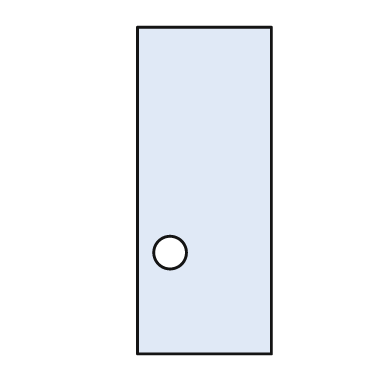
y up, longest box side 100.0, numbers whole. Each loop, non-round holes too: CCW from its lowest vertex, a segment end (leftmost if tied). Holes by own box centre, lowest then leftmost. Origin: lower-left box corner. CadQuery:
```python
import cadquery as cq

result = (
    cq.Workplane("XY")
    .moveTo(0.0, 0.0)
    .lineTo(41.0, 0.0)
    .lineTo(41.0, 100.0)
    .lineTo(0.0, 100.0)
    .close()
    .moveTo(10.0, 31.0)
    .circle(5.0)
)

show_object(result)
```